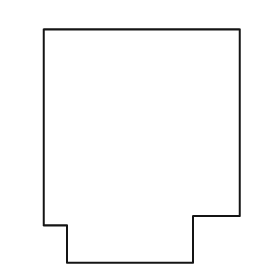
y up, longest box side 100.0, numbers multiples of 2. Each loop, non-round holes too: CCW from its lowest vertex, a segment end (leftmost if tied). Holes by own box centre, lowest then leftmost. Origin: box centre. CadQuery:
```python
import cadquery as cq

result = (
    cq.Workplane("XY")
    .moveTo(-32.0, -50.0)
    .lineTo(22.0, -50.0)
    .lineTo(22.0, -30.0)
    .lineTo(42.0, -30.0)
    .lineTo(42.0, 50.0)
    .lineTo(-42.0, 50.0)
    .lineTo(-42.0, -34.0)
    .lineTo(-32.0, -34.0)
    .close()
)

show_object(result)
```